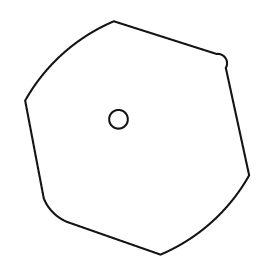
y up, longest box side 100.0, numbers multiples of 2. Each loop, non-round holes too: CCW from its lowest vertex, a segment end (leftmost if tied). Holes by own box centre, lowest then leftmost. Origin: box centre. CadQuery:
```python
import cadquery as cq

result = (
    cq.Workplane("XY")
    .moveTo(10.0, -50.0)
    .threePointArc((32.0, -36.0), (48.0, -16.0))
    .lineTo(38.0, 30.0)
    .threePointArc((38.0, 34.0), (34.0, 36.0))
    .lineTo(-10.0, 50.0)
    .threePointArc((-32.0, 36.0), (-48.0, 16.0))
    .lineTo(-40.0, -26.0)
    .threePointArc((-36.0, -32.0), (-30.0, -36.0))
    .close()
    .moveTo(-8.0, 8.0)
    .circle(4.0)
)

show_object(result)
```